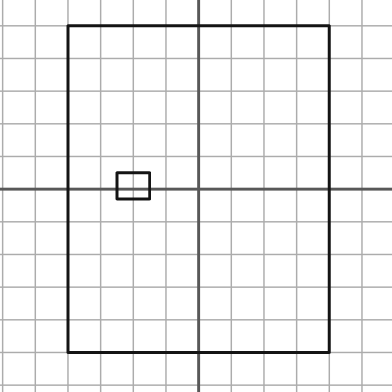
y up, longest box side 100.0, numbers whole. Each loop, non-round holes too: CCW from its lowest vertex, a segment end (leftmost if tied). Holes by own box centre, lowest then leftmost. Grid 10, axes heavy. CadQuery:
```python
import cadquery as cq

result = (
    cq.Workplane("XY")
    .moveTo(-40.0, -50.0)
    .lineTo(40.0, -50.0)
    .lineTo(40.0, 50.0)
    .lineTo(-40.0, 50.0)
    .close()
    .moveTo(-25.0, -3.0)
    .lineTo(-15.0, -3.0)
    .lineTo(-15.0, 5.0)
    .lineTo(-25.0, 5.0)
    .close()
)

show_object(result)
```